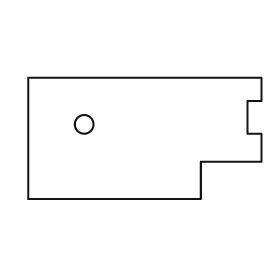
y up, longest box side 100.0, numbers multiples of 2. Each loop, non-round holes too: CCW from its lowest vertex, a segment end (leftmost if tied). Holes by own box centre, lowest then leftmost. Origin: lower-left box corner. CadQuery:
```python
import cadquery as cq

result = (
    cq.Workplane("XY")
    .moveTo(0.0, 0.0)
    .lineTo(74.0, 0.0)
    .lineTo(74.0, 16.0)
    .lineTo(100.0, 16.0)
    .lineTo(100.0, 28.0)
    .lineTo(94.0, 28.0)
    .lineTo(94.0, 42.0)
    .lineTo(100.0, 42.0)
    .lineTo(100.0, 52.0)
    .lineTo(0.0, 52.0)
    .close()
    .moveTo(24.0, 32.0)
    .circle(4.0)
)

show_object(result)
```